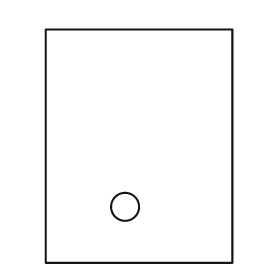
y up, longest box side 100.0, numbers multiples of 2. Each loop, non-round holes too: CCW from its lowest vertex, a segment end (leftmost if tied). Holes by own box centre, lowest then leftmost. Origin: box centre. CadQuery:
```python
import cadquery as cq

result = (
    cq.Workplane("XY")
    .moveTo(-40.0, -50.0)
    .lineTo(40.0, -50.0)
    .lineTo(40.0, 50.0)
    .lineTo(-40.0, 50.0)
    .close()
    .moveTo(-6.0, -26.0)
    .circle(6.0)
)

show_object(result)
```